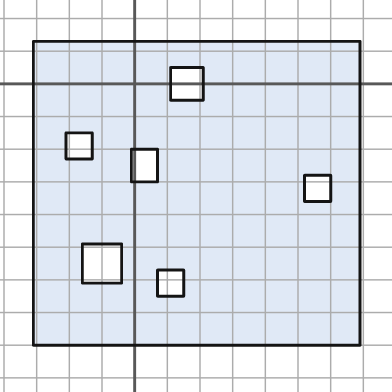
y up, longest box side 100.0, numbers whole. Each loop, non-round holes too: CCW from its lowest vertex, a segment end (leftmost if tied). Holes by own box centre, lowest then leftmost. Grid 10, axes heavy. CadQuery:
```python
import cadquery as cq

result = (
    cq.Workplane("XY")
    .moveTo(-31.0, -80.0)
    .lineTo(69.0, -80.0)
    .lineTo(69.0, 13.0)
    .lineTo(-31.0, 13.0)
    .close()
    .moveTo(7.0, -65.0)
    .lineTo(15.0, -65.0)
    .lineTo(15.0, -57.0)
    .lineTo(7.0, -57.0)
    .close()
    .moveTo(-16.0, -61.0)
    .lineTo(-4.0, -61.0)
    .lineTo(-4.0, -49.0)
    .lineTo(-16.0, -49.0)
    .close()
    .moveTo(52.0, -36.0)
    .lineTo(60.0, -36.0)
    .lineTo(60.0, -28.0)
    .lineTo(52.0, -28.0)
    .close()
    .moveTo(-1.0, -30.0)
    .lineTo(7.0, -30.0)
    .lineTo(7.0, -20.0)
    .lineTo(-1.0, -20.0)
    .close()
    .moveTo(-21.0, -23.0)
    .lineTo(-13.0, -23.0)
    .lineTo(-13.0, -15.0)
    .lineTo(-21.0, -15.0)
    .close()
    .moveTo(11.0, -5.0)
    .lineTo(21.0, -5.0)
    .lineTo(21.0, 5.0)
    .lineTo(11.0, 5.0)
    .close()
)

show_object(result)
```